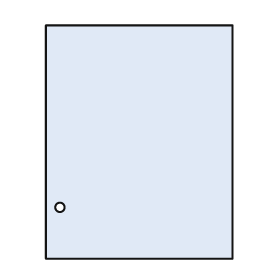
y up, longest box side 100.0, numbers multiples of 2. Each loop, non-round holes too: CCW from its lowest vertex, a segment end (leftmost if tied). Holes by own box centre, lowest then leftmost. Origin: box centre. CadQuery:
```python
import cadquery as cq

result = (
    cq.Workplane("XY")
    .moveTo(-40.0, -50.0)
    .lineTo(40.0, -50.0)
    .lineTo(40.0, 50.0)
    .lineTo(-40.0, 50.0)
    .close()
    .moveTo(-34.0, -28.0)
    .circle(2.0)
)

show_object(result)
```